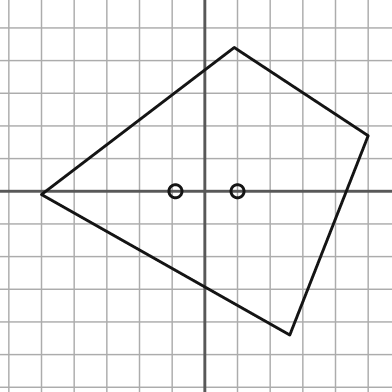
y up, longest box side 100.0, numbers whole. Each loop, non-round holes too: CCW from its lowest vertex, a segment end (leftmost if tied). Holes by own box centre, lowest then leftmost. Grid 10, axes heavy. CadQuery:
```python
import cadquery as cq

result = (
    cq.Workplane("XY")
    .moveTo(26.0, -44.0)
    .lineTo(50.0, 17.0)
    .lineTo(9.0, 44.0)
    .lineTo(-50.0, -1.0)
    .close()
    .moveTo(-9.0, 0.0)
    .circle(2.0)
    .moveTo(10.0, 0.0)
    .circle(2.0)
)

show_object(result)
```